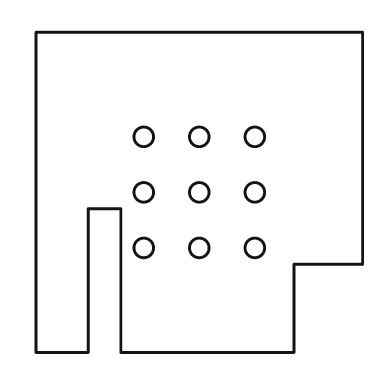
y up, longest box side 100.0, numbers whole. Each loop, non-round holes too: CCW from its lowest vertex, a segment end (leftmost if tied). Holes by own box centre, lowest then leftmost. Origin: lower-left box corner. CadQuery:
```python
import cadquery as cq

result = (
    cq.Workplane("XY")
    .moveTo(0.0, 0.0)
    .lineTo(16.0, 0.0)
    .lineTo(16.0, 44.0)
    .lineTo(26.0, 44.0)
    .lineTo(26.0, 0.0)
    .lineTo(79.0, 0.0)
    .lineTo(79.0, 27.0)
    .lineTo(100.0, 27.0)
    .lineTo(100.0, 98.0)
    .lineTo(0.0, 98.0)
    .close()
    .moveTo(33.0, 32.0)
    .circle(3.0)
    .moveTo(50.0, 32.0)
    .circle(3.0)
    .moveTo(67.0, 32.0)
    .circle(3.0)
    .moveTo(33.0, 49.0)
    .circle(3.0)
    .moveTo(50.0, 49.0)
    .circle(3.0)
    .moveTo(67.0, 49.0)
    .circle(3.0)
    .moveTo(33.0, 66.0)
    .circle(3.0)
    .moveTo(50.0, 66.0)
    .circle(3.0)
    .moveTo(67.0, 66.0)
    .circle(3.0)
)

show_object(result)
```